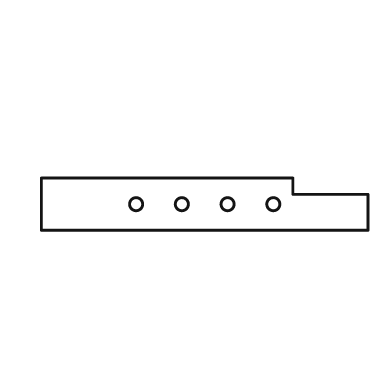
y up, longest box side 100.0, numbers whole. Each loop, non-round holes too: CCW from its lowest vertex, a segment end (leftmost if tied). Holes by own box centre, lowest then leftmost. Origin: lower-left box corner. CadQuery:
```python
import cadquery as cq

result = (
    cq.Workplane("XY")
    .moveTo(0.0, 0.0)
    .lineTo(100.0, 0.0)
    .lineTo(100.0, 11.0)
    .lineTo(77.0, 11.0)
    .lineTo(77.0, 16.0)
    .lineTo(0.0, 16.0)
    .close()
    .moveTo(29.0, 8.0)
    .circle(2.0)
    .moveTo(43.0, 8.0)
    .circle(2.0)
    .moveTo(57.0, 8.0)
    .circle(2.0)
    .moveTo(71.0, 8.0)
    .circle(2.0)
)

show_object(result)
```